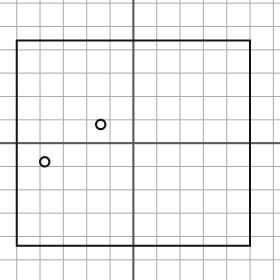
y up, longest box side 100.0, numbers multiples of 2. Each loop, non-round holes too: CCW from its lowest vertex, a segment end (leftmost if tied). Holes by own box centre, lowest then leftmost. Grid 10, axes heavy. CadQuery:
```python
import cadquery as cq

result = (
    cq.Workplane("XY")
    .moveTo(-50.0, -44.0)
    .lineTo(50.0, -44.0)
    .lineTo(50.0, 44.0)
    .lineTo(-50.0, 44.0)
    .close()
    .moveTo(-38.0, -8.0)
    .circle(2.0)
    .moveTo(-14.0, 8.0)
    .circle(2.0)
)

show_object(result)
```